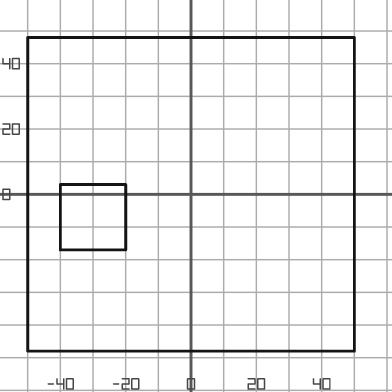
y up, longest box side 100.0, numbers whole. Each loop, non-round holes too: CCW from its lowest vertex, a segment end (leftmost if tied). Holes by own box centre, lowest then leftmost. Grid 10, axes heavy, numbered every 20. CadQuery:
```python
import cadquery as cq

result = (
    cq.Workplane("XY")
    .moveTo(-50.0, -48.0)
    .lineTo(50.0, -48.0)
    .lineTo(50.0, 48.0)
    .lineTo(-50.0, 48.0)
    .close()
    .moveTo(-40.0, -17.0)
    .lineTo(-20.0, -17.0)
    .lineTo(-20.0, 3.0)
    .lineTo(-40.0, 3.0)
    .close()
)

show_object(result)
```